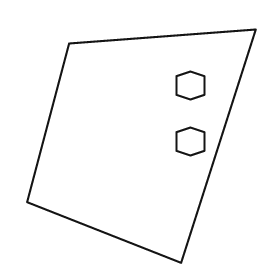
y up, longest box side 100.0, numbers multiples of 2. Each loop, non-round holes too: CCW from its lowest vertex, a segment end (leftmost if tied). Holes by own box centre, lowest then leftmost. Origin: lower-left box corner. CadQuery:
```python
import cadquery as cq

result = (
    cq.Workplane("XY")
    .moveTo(66.0, 0.0)
    .lineTo(98.0, 100.0)
    .lineTo(18.0, 94.0)
    .lineTo(0.0, 26.0)
    .close()
    .moveTo(70.0, 46.0)
    .lineTo(76.0, 48.0)
    .lineTo(76.0, 56.0)
    .lineTo(70.0, 58.0)
    .lineTo(64.0, 56.0)
    .lineTo(64.0, 48.0)
    .close()
    .moveTo(70.0, 70.0)
    .lineTo(76.0, 72.0)
    .lineTo(76.0, 80.0)
    .lineTo(70.0, 82.0)
    .lineTo(64.0, 80.0)
    .lineTo(64.0, 72.0)
    .close()
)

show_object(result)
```